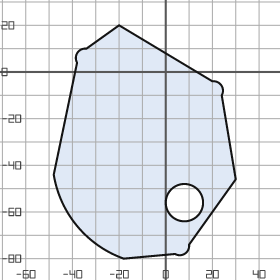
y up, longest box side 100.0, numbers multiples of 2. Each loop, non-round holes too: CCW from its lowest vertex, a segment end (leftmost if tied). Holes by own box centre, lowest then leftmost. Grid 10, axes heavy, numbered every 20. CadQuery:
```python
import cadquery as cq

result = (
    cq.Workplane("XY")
    .moveTo(-18.0, -80.0)
    .lineTo(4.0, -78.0)
    .threePointArc((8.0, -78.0), (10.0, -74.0))
    .lineTo(30.0, -46.0)
    .lineTo(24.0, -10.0)
    .threePointArc((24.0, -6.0), (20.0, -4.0))
    .lineTo(-20.0, 20.0)
    .lineTo(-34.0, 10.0)
    .threePointArc((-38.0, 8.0), (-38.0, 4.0))
    .lineTo(-48.0, -44.0)
    .threePointArc((-38.0, -66.0), (-18.0, -80.0))
    .close()
    .moveTo(8.0, -56.0)
    .circle(8.0)
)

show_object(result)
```